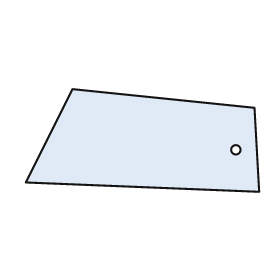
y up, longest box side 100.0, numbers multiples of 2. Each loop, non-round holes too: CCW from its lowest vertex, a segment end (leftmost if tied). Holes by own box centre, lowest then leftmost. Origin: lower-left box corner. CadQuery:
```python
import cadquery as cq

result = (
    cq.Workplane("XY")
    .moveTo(100.0, 0.0)
    .lineTo(98.0, 36.0)
    .lineTo(20.0, 44.0)
    .lineTo(0.0, 4.0)
    .close()
    .moveTo(90.0, 18.0)
    .circle(2.0)
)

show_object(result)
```